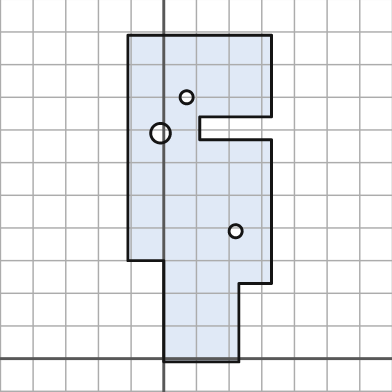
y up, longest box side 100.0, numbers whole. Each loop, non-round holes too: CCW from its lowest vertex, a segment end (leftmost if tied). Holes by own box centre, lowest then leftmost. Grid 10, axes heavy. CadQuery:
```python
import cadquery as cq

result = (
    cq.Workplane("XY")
    .moveTo(0.0, -1.0)
    .lineTo(23.0, -1.0)
    .lineTo(23.0, 23.0)
    .lineTo(33.0, 23.0)
    .lineTo(33.0, 67.0)
    .lineTo(11.0, 67.0)
    .lineTo(11.0, 74.0)
    .lineTo(33.0, 74.0)
    .lineTo(33.0, 99.0)
    .lineTo(-11.0, 99.0)
    .lineTo(-11.0, 30.0)
    .lineTo(0.0, 30.0)
    .close()
    .moveTo(22.0, 39.0)
    .circle(2.0)
    .moveTo(-1.0, 69.0)
    .circle(3.0)
    .moveTo(7.0, 80.0)
    .circle(2.0)
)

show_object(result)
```